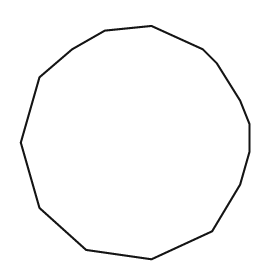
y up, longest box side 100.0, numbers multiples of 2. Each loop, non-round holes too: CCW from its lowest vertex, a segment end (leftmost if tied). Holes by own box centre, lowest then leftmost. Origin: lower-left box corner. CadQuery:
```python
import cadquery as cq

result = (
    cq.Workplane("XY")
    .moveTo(56.0, 0.0)
    .lineTo(82.0, 12.0)
    .lineTo(94.0, 32.0)
    .lineTo(98.0, 46.0)
    .lineTo(98.0, 58.0)
    .lineTo(94.0, 68.0)
    .lineTo(84.0, 84.0)
    .lineTo(78.0, 90.0)
    .lineTo(56.0, 100.0)
    .lineTo(36.0, 98.0)
    .lineTo(22.0, 90.0)
    .lineTo(8.0, 78.0)
    .lineTo(0.0, 50.0)
    .lineTo(8.0, 22.0)
    .lineTo(28.0, 4.0)
    .close()
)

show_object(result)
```